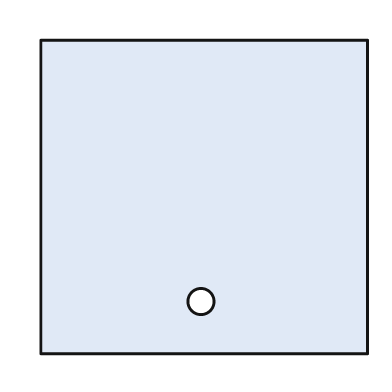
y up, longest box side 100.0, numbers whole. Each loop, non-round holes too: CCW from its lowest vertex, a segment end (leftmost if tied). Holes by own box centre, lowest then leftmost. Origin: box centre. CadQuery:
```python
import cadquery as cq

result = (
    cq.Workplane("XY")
    .moveTo(-50.0, -48.0)
    .lineTo(50.0, -48.0)
    .lineTo(50.0, 48.0)
    .lineTo(-50.0, 48.0)
    .close()
    .moveTo(-1.0, -32.0)
    .circle(4.0)
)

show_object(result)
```